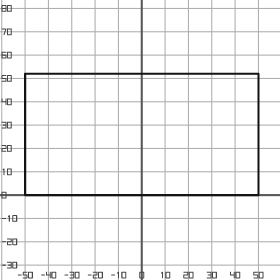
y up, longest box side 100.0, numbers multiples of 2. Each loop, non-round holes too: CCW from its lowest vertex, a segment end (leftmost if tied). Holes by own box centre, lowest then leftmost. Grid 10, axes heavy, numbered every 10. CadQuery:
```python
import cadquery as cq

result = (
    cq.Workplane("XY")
    .moveTo(-50.0, 0.0)
    .lineTo(50.0, 0.0)
    .lineTo(50.0, 52.0)
    .lineTo(-50.0, 52.0)
    .close()
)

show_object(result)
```